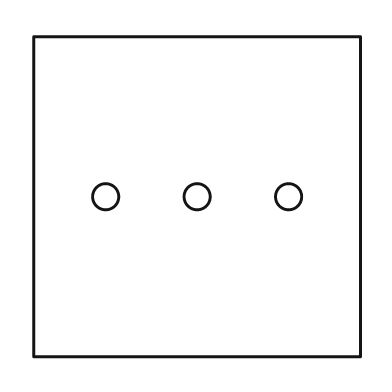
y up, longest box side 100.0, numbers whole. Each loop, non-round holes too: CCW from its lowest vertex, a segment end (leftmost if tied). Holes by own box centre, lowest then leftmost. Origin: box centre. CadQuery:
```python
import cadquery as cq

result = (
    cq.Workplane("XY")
    .moveTo(-50.0, -49.0)
    .lineTo(50.0, -49.0)
    .lineTo(50.0, 49.0)
    .lineTo(-50.0, 49.0)
    .close()
    .moveTo(-28.0, 0.0)
    .circle(4.0)
    .moveTo(0.0, 0.0)
    .circle(4.0)
    .moveTo(28.0, 0.0)
    .circle(4.0)
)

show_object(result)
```